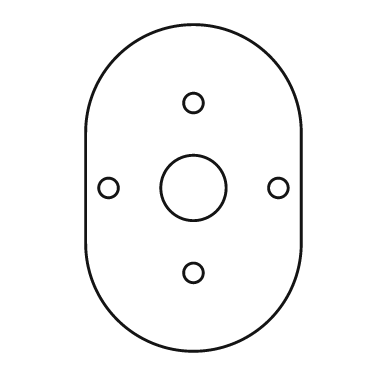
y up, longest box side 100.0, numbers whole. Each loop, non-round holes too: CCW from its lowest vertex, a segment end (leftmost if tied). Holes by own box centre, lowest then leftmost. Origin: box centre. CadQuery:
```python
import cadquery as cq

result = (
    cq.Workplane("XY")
    .moveTo(-33.0, -17.0)
    .threePointArc((0.0, -50.0), (33.0, -17.0))
    .lineTo(33.0, 17.0)
    .threePointArc((0.0, 50.0), (-33.0, 17.0))
    .close()
    .moveTo(0.0, -26.0)
    .circle(3.0)
    .moveTo(-26.0, 0.0)
    .circle(3.0)
    .moveTo(0.0, 0.0)
    .circle(10.0)
    .moveTo(26.0, 0.0)
    .circle(3.0)
    .moveTo(0.0, 26.0)
    .circle(3.0)
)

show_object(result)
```